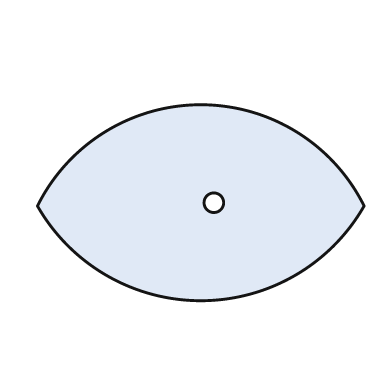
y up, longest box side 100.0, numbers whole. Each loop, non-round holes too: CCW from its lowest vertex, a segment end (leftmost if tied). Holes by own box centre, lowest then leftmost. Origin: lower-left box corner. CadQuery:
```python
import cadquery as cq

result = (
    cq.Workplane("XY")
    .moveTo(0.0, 29.0)
    .threePointArc((50.0, 0.0), (100.0, 29.0))
    .threePointArc((50.0, 60.0), (0.0, 29.0))
    .close()
    .moveTo(54.0, 30.0)
    .circle(3.0)
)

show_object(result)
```